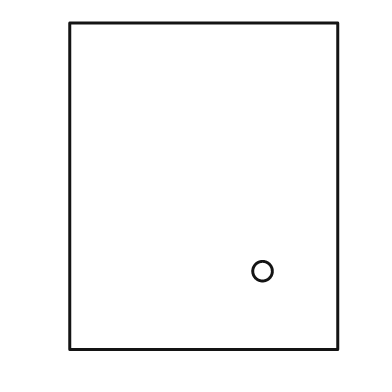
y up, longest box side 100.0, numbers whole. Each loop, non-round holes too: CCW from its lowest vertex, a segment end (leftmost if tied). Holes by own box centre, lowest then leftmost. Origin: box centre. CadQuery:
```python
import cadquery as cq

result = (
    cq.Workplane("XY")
    .moveTo(-41.0, -50.0)
    .lineTo(41.0, -50.0)
    .lineTo(41.0, 50.0)
    .lineTo(-41.0, 50.0)
    .close()
    .moveTo(18.0, -26.0)
    .circle(3.0)
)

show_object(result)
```